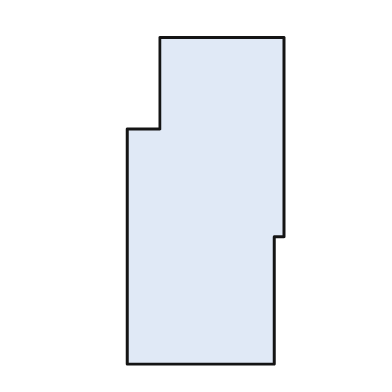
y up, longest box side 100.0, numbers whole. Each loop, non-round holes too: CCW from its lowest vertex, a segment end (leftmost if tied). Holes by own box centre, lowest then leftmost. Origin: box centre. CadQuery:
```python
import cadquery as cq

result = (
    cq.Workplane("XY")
    .moveTo(-24.0, -50.0)
    .lineTo(21.0, -50.0)
    .lineTo(21.0, -11.0)
    .lineTo(24.0, -11.0)
    .lineTo(24.0, 50.0)
    .lineTo(-14.0, 50.0)
    .lineTo(-14.0, 22.0)
    .lineTo(-24.0, 22.0)
    .close()
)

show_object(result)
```